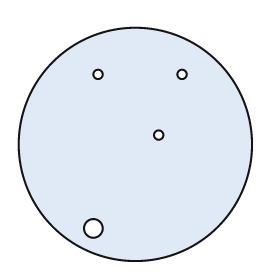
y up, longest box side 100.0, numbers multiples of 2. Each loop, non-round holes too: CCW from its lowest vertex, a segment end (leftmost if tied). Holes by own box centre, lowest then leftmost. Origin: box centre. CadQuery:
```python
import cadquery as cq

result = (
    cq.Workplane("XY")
    .moveTo(0.0, 0.0)
    .circle(50.0)
    .moveTo(-18.0, -36.0)
    .circle(4.0)
    .moveTo(10.0, 4.0)
    .circle(2.0)
    .moveTo(-16.0, 30.0)
    .circle(2.0)
    .moveTo(20.0, 30.0)
    .circle(2.0)
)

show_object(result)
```